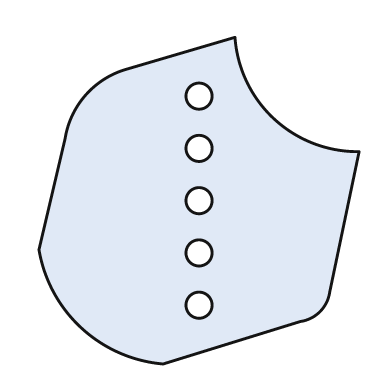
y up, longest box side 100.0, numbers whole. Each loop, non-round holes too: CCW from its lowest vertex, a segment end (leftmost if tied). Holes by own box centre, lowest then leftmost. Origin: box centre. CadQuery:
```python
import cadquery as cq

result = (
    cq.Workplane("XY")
    .moveTo(-11.0, -50.0)
    .lineTo(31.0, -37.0)
    .threePointArc((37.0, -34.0), (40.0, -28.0))
    .lineTo(49.0, 15.0)
    .threePointArc((23.0, 25.0), (11.0, 50.0))
    .lineTo(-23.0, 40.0)
    .threePointArc((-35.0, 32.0), (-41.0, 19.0))
    .lineTo(-49.0, -15.0)
    .threePointArc((-36.0, -39.0), (-11.0, -50.0))
    .close()
    .moveTo(0.0, -32.0)
    .circle(4.0)
    .moveTo(0.0, -16.0)
    .circle(4.0)
    .moveTo(0.0, 0.0)
    .circle(4.0)
    .moveTo(0.0, 16.0)
    .circle(4.0)
    .moveTo(0.0, 32.0)
    .circle(4.0)
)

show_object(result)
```